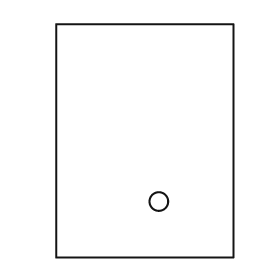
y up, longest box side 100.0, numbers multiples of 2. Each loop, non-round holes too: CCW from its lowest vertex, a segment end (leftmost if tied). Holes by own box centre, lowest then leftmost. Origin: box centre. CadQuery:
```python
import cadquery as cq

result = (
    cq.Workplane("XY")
    .moveTo(-38.0, -50.0)
    .lineTo(38.0, -50.0)
    .lineTo(38.0, 50.0)
    .lineTo(-38.0, 50.0)
    .close()
    .moveTo(6.0, -26.0)
    .circle(4.0)
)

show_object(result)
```